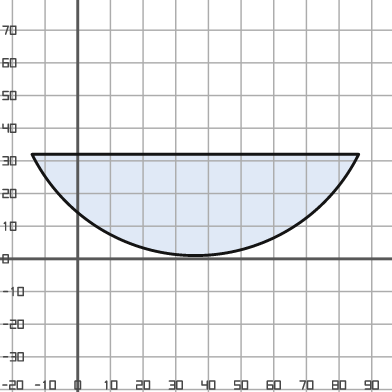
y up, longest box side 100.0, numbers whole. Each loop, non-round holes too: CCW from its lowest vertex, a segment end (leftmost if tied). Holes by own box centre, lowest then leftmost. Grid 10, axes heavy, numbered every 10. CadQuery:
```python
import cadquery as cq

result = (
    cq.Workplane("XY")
    .moveTo(-14.0, 32.0)
    .threePointArc((36.0, 1.0), (86.0, 32.0))
    .close()
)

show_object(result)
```